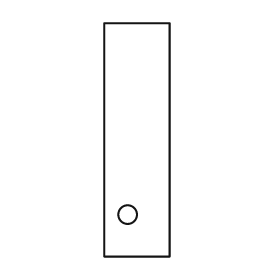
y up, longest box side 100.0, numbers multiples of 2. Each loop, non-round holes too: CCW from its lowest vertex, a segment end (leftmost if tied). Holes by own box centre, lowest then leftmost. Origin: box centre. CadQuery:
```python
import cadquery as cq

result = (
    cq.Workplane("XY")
    .moveTo(-14.0, -50.0)
    .lineTo(14.0, -50.0)
    .lineTo(14.0, 50.0)
    .lineTo(-14.0, 50.0)
    .close()
    .moveTo(-4.0, -32.0)
    .circle(4.0)
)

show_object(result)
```